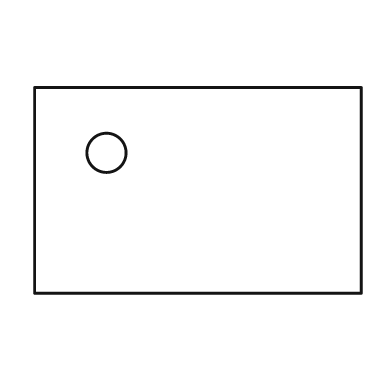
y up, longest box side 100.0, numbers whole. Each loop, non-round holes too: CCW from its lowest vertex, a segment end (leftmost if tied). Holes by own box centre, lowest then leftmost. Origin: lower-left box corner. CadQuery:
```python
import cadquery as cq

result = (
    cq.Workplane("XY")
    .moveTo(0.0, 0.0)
    .lineTo(100.0, 0.0)
    .lineTo(100.0, 63.0)
    .lineTo(0.0, 63.0)
    .close()
    .moveTo(22.0, 43.0)
    .circle(6.0)
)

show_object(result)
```